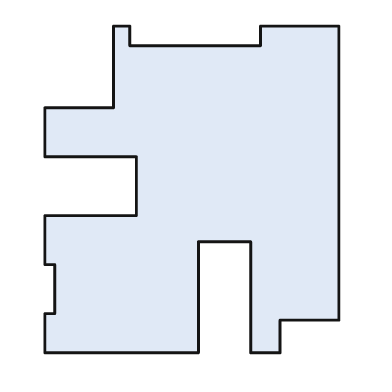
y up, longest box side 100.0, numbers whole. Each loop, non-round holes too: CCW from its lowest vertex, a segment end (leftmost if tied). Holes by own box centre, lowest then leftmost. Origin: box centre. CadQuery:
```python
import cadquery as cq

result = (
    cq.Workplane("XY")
    .moveTo(-45.0, -50.0)
    .lineTo(2.0, -50.0)
    .lineTo(2.0, -16.0)
    .lineTo(18.0, -16.0)
    .lineTo(18.0, -50.0)
    .lineTo(27.0, -50.0)
    .lineTo(27.0, -40.0)
    .lineTo(45.0, -40.0)
    .lineTo(45.0, 50.0)
    .lineTo(21.0, 50.0)
    .lineTo(21.0, 44.0)
    .lineTo(-19.0, 44.0)
    .lineTo(-19.0, 50.0)
    .lineTo(-24.0, 50.0)
    .lineTo(-24.0, 25.0)
    .lineTo(-45.0, 25.0)
    .lineTo(-45.0, 10.0)
    .lineTo(-17.0, 10.0)
    .lineTo(-17.0, -8.0)
    .lineTo(-45.0, -8.0)
    .lineTo(-45.0, -23.0)
    .lineTo(-42.0, -23.0)
    .lineTo(-42.0, -38.0)
    .lineTo(-45.0, -38.0)
    .close()
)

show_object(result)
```